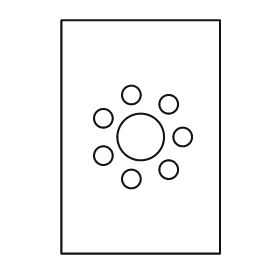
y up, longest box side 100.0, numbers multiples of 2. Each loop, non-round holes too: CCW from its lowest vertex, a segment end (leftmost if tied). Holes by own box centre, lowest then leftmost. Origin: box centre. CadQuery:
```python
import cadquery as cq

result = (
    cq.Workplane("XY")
    .moveTo(-34.0, -50.0)
    .lineTo(34.0, -50.0)
    .lineTo(34.0, 50.0)
    .lineTo(-34.0, 50.0)
    .close()
    .moveTo(-4.0, -18.0)
    .circle(4.0)
    .moveTo(12.0, -14.0)
    .circle(4.0)
    .moveTo(-16.0, -8.0)
    .circle(4.0)
    .moveTo(0.0, 0.0)
    .circle(10.0)
    .moveTo(18.0, 0.0)
    .circle(4.0)
    .moveTo(-16.0, 8.0)
    .circle(4.0)
    .moveTo(12.0, 14.0)
    .circle(4.0)
    .moveTo(-4.0, 18.0)
    .circle(4.0)
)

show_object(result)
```